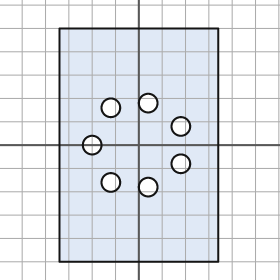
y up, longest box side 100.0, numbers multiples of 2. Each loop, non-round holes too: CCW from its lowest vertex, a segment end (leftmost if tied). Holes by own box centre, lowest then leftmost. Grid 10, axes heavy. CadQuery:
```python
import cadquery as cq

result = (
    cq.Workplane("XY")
    .moveTo(-34.0, -50.0)
    .lineTo(34.0, -50.0)
    .lineTo(34.0, 50.0)
    .lineTo(-34.0, 50.0)
    .close()
    .moveTo(4.0, -18.0)
    .circle(4.0)
    .moveTo(-12.0, -16.0)
    .circle(4.0)
    .moveTo(18.0, -8.0)
    .circle(4.0)
    .moveTo(-20.0, 0.0)
    .circle(4.0)
    .moveTo(18.0, 8.0)
    .circle(4.0)
    .moveTo(-12.0, 16.0)
    .circle(4.0)
    .moveTo(4.0, 18.0)
    .circle(4.0)
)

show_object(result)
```